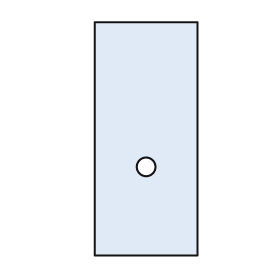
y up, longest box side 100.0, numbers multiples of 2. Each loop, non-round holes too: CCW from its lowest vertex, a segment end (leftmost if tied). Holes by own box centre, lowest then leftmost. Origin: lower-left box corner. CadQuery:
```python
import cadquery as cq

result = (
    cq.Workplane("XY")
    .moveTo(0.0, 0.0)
    .lineTo(44.0, 0.0)
    .lineTo(44.0, 100.0)
    .lineTo(0.0, 100.0)
    .close()
    .moveTo(22.0, 38.0)
    .circle(4.0)
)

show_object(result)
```